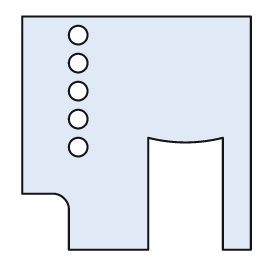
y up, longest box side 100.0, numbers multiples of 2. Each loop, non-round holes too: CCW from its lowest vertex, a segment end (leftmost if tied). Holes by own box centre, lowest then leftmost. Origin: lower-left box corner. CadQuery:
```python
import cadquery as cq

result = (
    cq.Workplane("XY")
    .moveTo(20.0, 0.0)
    .lineTo(54.0, 0.0)
    .lineTo(54.0, 48.0)
    .threePointArc((70.0, 46.0), (86.0, 48.0))
    .lineTo(86.0, 0.0)
    .lineTo(98.0, 0.0)
    .lineTo(98.0, 100.0)
    .lineTo(0.0, 100.0)
    .lineTo(0.0, 24.0)
    .lineTo(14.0, 24.0)
    .threePointArc((18.0, 22.0), (20.0, 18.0))
    .close()
    .moveTo(24.0, 44.0)
    .circle(4.0)
    .moveTo(24.0, 56.0)
    .circle(4.0)
    .moveTo(24.0, 68.0)
    .circle(4.0)
    .moveTo(24.0, 80.0)
    .circle(4.0)
    .moveTo(24.0, 92.0)
    .circle(4.0)
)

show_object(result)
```